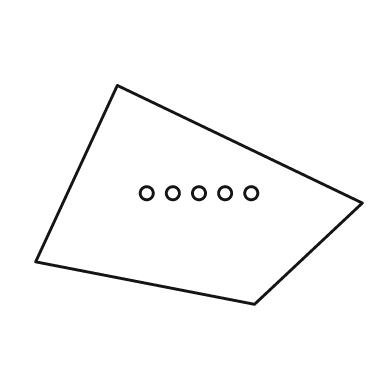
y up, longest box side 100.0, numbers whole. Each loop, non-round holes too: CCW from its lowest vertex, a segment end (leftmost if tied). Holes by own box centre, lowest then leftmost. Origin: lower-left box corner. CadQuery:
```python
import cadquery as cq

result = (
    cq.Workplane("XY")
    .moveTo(67.0, 0.0)
    .lineTo(100.0, 31.0)
    .lineTo(25.0, 67.0)
    .lineTo(0.0, 13.0)
    .close()
    .moveTo(34.0, 34.0)
    .circle(2.0)
    .moveTo(42.0, 34.0)
    .circle(2.0)
    .moveTo(50.0, 34.0)
    .circle(2.0)
    .moveTo(58.0, 34.0)
    .circle(2.0)
    .moveTo(66.0, 34.0)
    .circle(2.0)
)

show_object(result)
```